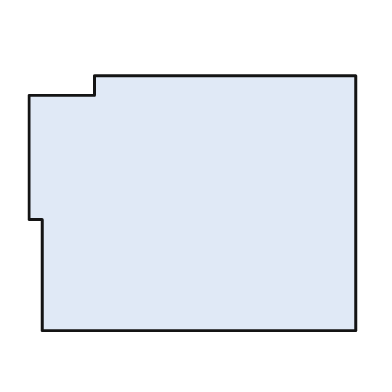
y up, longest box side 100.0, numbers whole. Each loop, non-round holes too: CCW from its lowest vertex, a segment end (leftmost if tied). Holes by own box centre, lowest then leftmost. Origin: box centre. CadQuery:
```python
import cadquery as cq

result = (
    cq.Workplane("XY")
    .moveTo(-46.0, -39.0)
    .lineTo(50.0, -39.0)
    .lineTo(50.0, 39.0)
    .lineTo(-30.0, 39.0)
    .lineTo(-30.0, 33.0)
    .lineTo(-50.0, 33.0)
    .lineTo(-50.0, -5.0)
    .lineTo(-46.0, -5.0)
    .close()
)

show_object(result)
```